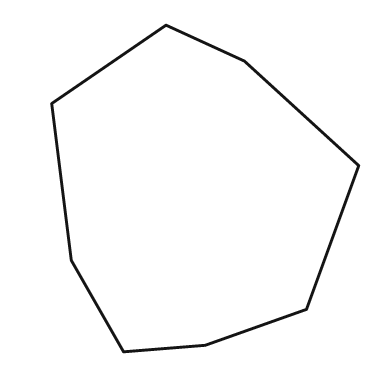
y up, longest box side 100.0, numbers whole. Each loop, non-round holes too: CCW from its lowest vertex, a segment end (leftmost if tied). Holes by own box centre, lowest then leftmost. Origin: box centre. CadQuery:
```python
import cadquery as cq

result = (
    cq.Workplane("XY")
    .moveTo(-25.0, -50.0)
    .lineTo(0.0, -48.0)
    .lineTo(31.0, -37.0)
    .lineTo(47.0, 7.0)
    .lineTo(12.0, 39.0)
    .lineTo(-12.0, 50.0)
    .lineTo(-47.0, 26.0)
    .lineTo(-41.0, -22.0)
    .close()
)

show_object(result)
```